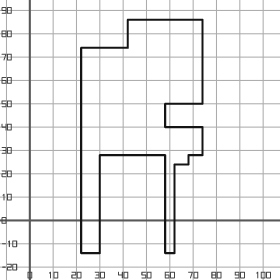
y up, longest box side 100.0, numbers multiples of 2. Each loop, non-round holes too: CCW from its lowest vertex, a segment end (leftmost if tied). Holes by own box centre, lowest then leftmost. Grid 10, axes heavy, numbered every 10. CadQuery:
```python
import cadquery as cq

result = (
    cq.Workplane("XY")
    .moveTo(22.0, -14.0)
    .lineTo(30.0, -14.0)
    .lineTo(30.0, 28.0)
    .lineTo(58.0, 28.0)
    .lineTo(58.0, -14.0)
    .lineTo(62.0, -14.0)
    .lineTo(62.0, 24.0)
    .lineTo(68.0, 24.0)
    .lineTo(68.0, 28.0)
    .lineTo(74.0, 28.0)
    .lineTo(74.0, 40.0)
    .lineTo(58.0, 40.0)
    .lineTo(58.0, 50.0)
    .lineTo(74.0, 50.0)
    .lineTo(74.0, 86.0)
    .lineTo(42.0, 86.0)
    .lineTo(42.0, 74.0)
    .lineTo(22.0, 74.0)
    .close()
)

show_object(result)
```